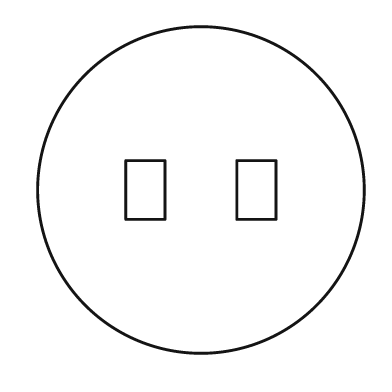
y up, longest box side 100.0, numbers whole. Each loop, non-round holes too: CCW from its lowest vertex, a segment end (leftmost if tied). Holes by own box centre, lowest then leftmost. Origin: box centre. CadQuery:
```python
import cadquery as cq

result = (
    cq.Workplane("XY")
    .moveTo(0.0, 0.0)
    .circle(50.0)
    .moveTo(-23.0, -9.0)
    .lineTo(-11.0, -9.0)
    .lineTo(-11.0, 9.0)
    .lineTo(-23.0, 9.0)
    .close()
    .moveTo(11.0, -9.0)
    .lineTo(23.0, -9.0)
    .lineTo(23.0, 9.0)
    .lineTo(11.0, 9.0)
    .close()
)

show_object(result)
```